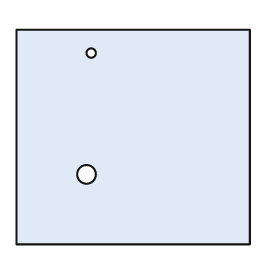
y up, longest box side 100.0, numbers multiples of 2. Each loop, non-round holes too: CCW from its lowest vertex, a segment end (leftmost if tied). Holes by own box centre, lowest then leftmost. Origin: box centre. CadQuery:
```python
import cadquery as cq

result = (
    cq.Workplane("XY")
    .moveTo(-50.0, -46.0)
    .lineTo(50.0, -46.0)
    .lineTo(50.0, 46.0)
    .lineTo(-50.0, 46.0)
    .close()
    .moveTo(-20.0, -16.0)
    .circle(4.0)
    .moveTo(-18.0, 36.0)
    .circle(2.0)
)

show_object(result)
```